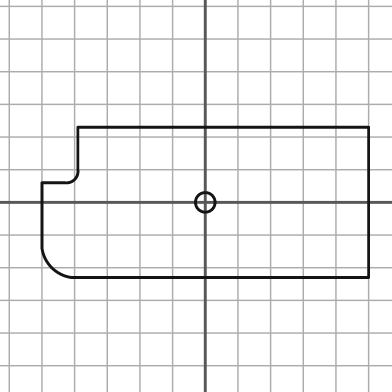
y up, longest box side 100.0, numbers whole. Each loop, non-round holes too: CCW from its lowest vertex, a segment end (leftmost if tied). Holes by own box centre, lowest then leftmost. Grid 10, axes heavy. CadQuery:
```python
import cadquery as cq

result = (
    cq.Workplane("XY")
    .moveTo(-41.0, -23.0)
    .lineTo(50.0, -23.0)
    .lineTo(50.0, 23.0)
    .lineTo(-39.0, 23.0)
    .lineTo(-39.0, 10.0)
    .threePointArc((-40.0, 7.0), (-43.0, 6.0))
    .lineTo(-50.0, 6.0)
    .lineTo(-50.0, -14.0)
    .threePointArc((-47.0, -20.0), (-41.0, -23.0))
    .close()
    .moveTo(0.0, 0.0)
    .circle(3.0)
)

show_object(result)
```